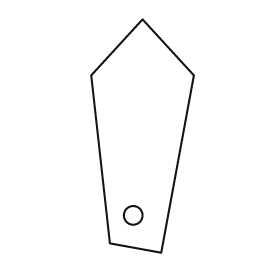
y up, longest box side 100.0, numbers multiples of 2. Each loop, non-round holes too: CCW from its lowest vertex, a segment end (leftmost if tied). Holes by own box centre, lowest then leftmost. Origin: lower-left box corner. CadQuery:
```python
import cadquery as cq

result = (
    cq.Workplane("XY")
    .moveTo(30.0, 0.0)
    .lineTo(44.0, 76.0)
    .lineTo(22.0, 100.0)
    .lineTo(0.0, 76.0)
    .lineTo(8.0, 4.0)
    .close()
    .moveTo(18.0, 16.0)
    .circle(4.0)
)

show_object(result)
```